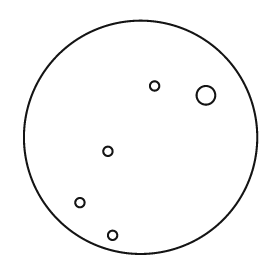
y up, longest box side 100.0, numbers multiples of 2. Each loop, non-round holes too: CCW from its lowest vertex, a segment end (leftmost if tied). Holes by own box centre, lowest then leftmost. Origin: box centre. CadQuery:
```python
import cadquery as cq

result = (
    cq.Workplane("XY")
    .moveTo(0.0, 0.0)
    .circle(50.0)
    .moveTo(-12.0, -42.0)
    .circle(2.0)
    .moveTo(-26.0, -28.0)
    .circle(2.0)
    .moveTo(-14.0, -6.0)
    .circle(2.0)
    .moveTo(28.0, 18.0)
    .circle(4.0)
    .moveTo(6.0, 22.0)
    .circle(2.0)
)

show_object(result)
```